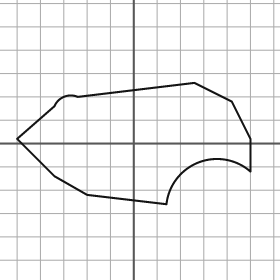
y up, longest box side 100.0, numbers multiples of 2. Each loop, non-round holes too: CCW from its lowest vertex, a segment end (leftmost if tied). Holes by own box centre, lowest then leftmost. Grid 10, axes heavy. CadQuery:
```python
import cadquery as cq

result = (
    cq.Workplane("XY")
    .moveTo(14.0, -26.0)
    .threePointArc((28.0, -8.0), (50.0, -12.0))
    .lineTo(50.0, 2.0)
    .lineTo(42.0, 18.0)
    .lineTo(26.0, 26.0)
    .lineTo(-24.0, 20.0)
    .threePointArc((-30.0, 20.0), (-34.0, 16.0))
    .lineTo(-50.0, 2.0)
    .lineTo(-34.0, -14.0)
    .lineTo(-20.0, -22.0)
    .close()
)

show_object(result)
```